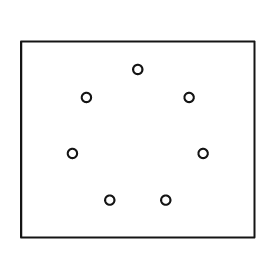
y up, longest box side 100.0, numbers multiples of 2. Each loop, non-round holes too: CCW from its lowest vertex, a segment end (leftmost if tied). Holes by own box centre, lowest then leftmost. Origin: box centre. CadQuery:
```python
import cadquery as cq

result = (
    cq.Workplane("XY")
    .moveTo(-50.0, -42.0)
    .lineTo(50.0, -42.0)
    .lineTo(50.0, 42.0)
    .lineTo(-50.0, 42.0)
    .close()
    .moveTo(-12.0, -26.0)
    .circle(2.0)
    .moveTo(12.0, -26.0)
    .circle(2.0)
    .moveTo(-28.0, -6.0)
    .circle(2.0)
    .moveTo(28.0, -6.0)
    .circle(2.0)
    .moveTo(-22.0, 18.0)
    .circle(2.0)
    .moveTo(22.0, 18.0)
    .circle(2.0)
    .moveTo(0.0, 30.0)
    .circle(2.0)
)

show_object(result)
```